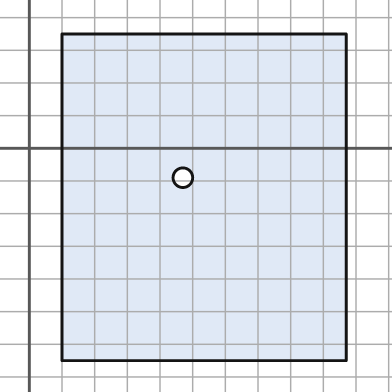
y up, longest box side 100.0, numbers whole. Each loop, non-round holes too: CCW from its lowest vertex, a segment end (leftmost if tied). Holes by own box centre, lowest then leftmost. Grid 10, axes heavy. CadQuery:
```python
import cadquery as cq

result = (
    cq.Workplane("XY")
    .moveTo(10.0, -65.0)
    .lineTo(97.0, -65.0)
    .lineTo(97.0, 35.0)
    .lineTo(10.0, 35.0)
    .close()
    .moveTo(47.0, -9.0)
    .circle(3.0)
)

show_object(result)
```